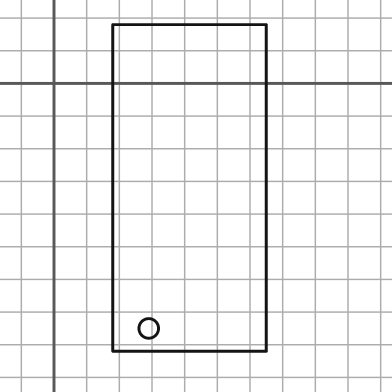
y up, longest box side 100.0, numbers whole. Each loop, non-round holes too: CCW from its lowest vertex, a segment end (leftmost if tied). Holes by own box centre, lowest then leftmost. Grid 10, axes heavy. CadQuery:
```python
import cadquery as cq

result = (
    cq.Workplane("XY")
    .moveTo(18.0, -82.0)
    .lineTo(65.0, -82.0)
    .lineTo(65.0, 18.0)
    .lineTo(18.0, 18.0)
    .close()
    .moveTo(29.0, -75.0)
    .circle(3.0)
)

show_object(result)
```